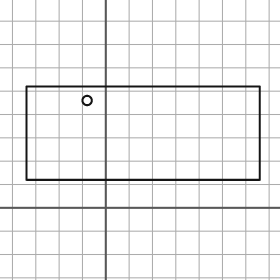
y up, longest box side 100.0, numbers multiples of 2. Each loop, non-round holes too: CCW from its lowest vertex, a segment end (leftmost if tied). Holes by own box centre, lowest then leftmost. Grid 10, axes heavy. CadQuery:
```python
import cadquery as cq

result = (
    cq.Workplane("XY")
    .moveTo(-34.0, 12.0)
    .lineTo(66.0, 12.0)
    .lineTo(66.0, 52.0)
    .lineTo(-34.0, 52.0)
    .close()
    .moveTo(-8.0, 46.0)
    .circle(2.0)
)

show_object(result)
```